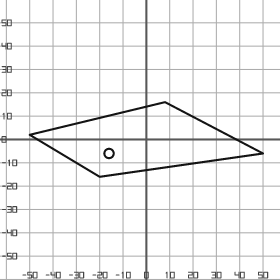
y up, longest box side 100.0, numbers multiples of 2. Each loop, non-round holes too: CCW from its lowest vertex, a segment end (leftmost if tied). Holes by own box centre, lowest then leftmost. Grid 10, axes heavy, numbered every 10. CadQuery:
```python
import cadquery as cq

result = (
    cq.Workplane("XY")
    .moveTo(-20.0, -16.0)
    .lineTo(50.0, -6.0)
    .lineTo(8.0, 16.0)
    .lineTo(-50.0, 2.0)
    .close()
    .moveTo(-16.0, -6.0)
    .circle(2.0)
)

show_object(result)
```